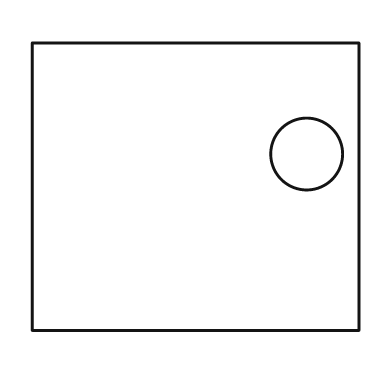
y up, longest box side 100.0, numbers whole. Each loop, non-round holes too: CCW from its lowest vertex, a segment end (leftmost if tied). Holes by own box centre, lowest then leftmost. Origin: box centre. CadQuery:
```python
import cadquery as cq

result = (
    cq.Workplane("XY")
    .moveTo(-50.0, -44.0)
    .lineTo(50.0, -44.0)
    .lineTo(50.0, 44.0)
    .lineTo(-50.0, 44.0)
    .close()
    .moveTo(34.0, 10.0)
    .circle(11.0)
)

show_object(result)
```